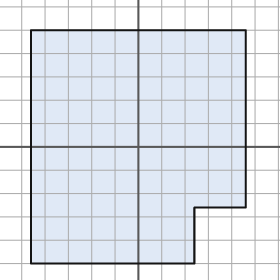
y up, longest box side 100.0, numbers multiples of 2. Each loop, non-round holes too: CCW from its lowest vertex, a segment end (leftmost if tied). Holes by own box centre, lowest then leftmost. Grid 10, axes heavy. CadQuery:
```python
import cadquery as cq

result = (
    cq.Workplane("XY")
    .moveTo(-46.0, -50.0)
    .lineTo(24.0, -50.0)
    .lineTo(24.0, -26.0)
    .lineTo(46.0, -26.0)
    .lineTo(46.0, 50.0)
    .lineTo(-46.0, 50.0)
    .close()
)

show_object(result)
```